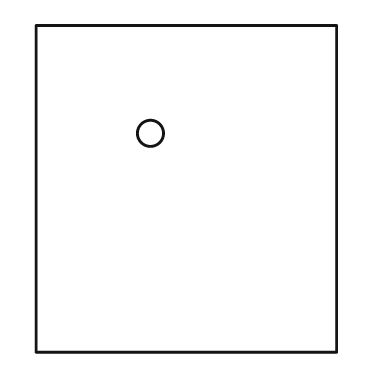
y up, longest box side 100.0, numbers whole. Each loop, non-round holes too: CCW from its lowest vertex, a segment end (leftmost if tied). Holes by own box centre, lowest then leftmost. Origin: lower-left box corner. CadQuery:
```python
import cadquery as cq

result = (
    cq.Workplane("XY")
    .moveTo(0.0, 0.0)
    .lineTo(92.0, 0.0)
    .lineTo(92.0, 100.0)
    .lineTo(0.0, 100.0)
    .close()
    .moveTo(35.0, 67.0)
    .circle(4.0)
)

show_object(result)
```